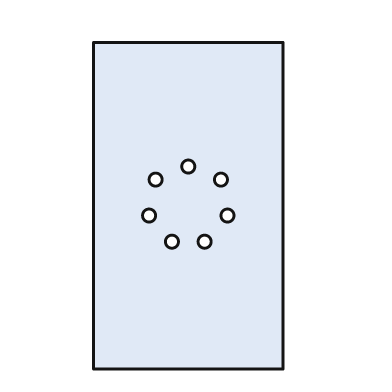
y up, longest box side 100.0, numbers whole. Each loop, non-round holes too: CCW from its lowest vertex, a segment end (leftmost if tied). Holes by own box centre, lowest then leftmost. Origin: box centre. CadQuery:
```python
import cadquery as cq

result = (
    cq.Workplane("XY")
    .moveTo(-29.0, -50.0)
    .lineTo(29.0, -50.0)
    .lineTo(29.0, 50.0)
    .lineTo(-29.0, 50.0)
    .close()
    .moveTo(-5.0, -11.0)
    .circle(2.0)
    .moveTo(5.0, -11.0)
    .circle(2.0)
    .moveTo(-12.0, -3.0)
    .circle(2.0)
    .moveTo(12.0, -3.0)
    .circle(2.0)
    .moveTo(-10.0, 8.0)
    .circle(2.0)
    .moveTo(10.0, 8.0)
    .circle(2.0)
    .moveTo(0.0, 12.0)
    .circle(2.0)
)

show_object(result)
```